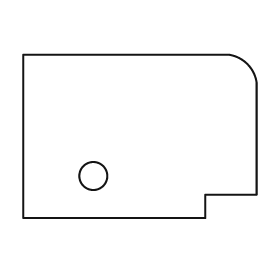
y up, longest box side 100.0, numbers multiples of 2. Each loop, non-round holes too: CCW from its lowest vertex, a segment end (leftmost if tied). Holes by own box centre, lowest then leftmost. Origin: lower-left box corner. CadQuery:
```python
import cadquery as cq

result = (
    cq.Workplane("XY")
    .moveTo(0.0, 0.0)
    .lineTo(78.0, 0.0)
    .lineTo(78.0, 10.0)
    .lineTo(100.0, 10.0)
    .lineTo(100.0, 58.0)
    .threePointArc((96.0, 66.0), (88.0, 70.0))
    .lineTo(0.0, 70.0)
    .close()
    .moveTo(30.0, 18.0)
    .circle(6.0)
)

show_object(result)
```